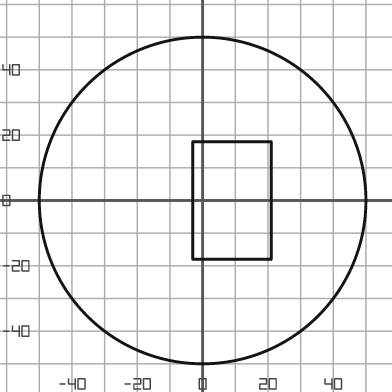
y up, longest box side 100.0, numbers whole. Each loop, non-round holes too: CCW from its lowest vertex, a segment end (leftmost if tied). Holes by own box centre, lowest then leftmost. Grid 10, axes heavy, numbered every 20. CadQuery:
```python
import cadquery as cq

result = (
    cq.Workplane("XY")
    .moveTo(0.0, 0.0)
    .circle(50.0)
    .moveTo(-3.0, -18.0)
    .lineTo(21.0, -18.0)
    .lineTo(21.0, 18.0)
    .lineTo(-3.0, 18.0)
    .close()
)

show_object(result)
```